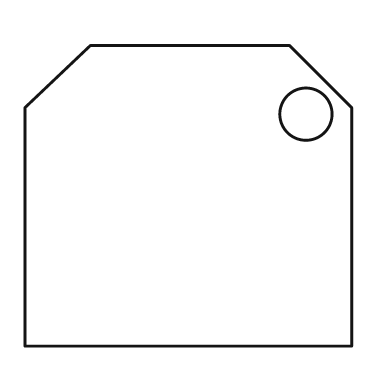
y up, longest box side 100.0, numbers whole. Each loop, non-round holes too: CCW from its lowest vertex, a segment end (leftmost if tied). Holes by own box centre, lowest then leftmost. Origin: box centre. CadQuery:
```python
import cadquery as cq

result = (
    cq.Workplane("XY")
    .moveTo(-50.0, -46.0)
    .lineTo(50.0, -46.0)
    .lineTo(50.0, 27.0)
    .lineTo(31.0, 46.0)
    .lineTo(-30.0, 46.0)
    .lineTo(-50.0, 27.0)
    .close()
    .moveTo(36.0, 25.0)
    .circle(8.0)
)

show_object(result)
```